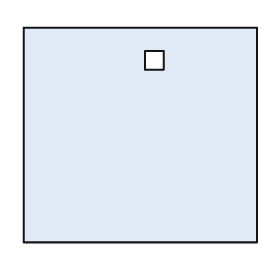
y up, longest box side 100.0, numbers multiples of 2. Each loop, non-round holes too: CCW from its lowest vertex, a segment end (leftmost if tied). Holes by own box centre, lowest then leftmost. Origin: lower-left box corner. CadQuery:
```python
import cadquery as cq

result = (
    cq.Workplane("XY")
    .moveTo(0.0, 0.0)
    .lineTo(100.0, 0.0)
    .lineTo(100.0, 92.0)
    .lineTo(0.0, 92.0)
    .close()
    .moveTo(52.0, 74.0)
    .lineTo(60.0, 74.0)
    .lineTo(60.0, 82.0)
    .lineTo(52.0, 82.0)
    .close()
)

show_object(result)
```